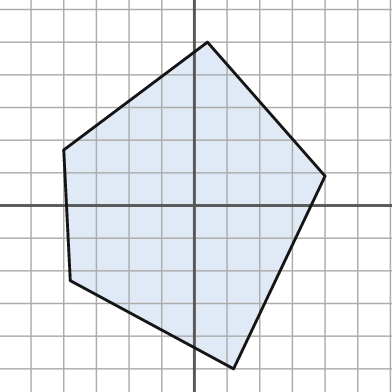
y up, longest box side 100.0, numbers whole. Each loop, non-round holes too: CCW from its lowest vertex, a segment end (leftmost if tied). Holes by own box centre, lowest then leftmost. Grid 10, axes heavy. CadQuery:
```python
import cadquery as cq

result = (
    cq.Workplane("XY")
    .moveTo(12.0, -50.0)
    .lineTo(40.0, 9.0)
    .lineTo(4.0, 50.0)
    .lineTo(-40.0, 17.0)
    .lineTo(-38.0, -23.0)
    .close()
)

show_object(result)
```